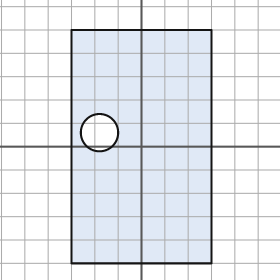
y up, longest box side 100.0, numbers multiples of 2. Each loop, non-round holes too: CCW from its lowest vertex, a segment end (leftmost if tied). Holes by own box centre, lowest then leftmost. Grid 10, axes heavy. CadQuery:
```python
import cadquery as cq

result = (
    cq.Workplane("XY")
    .moveTo(-30.0, -50.0)
    .lineTo(30.0, -50.0)
    .lineTo(30.0, 50.0)
    .lineTo(-30.0, 50.0)
    .close()
    .moveTo(-18.0, 6.0)
    .circle(8.0)
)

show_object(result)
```